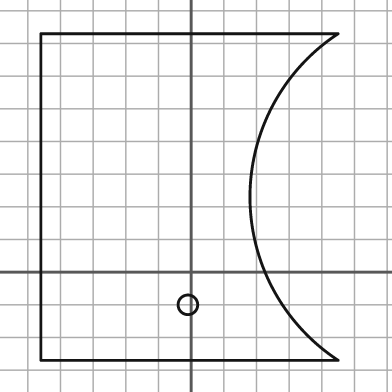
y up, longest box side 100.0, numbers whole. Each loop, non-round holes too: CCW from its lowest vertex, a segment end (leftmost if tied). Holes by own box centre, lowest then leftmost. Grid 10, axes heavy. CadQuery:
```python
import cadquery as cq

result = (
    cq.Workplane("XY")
    .moveTo(-46.0, -27.0)
    .lineTo(45.0, -27.0)
    .threePointArc((18.0, 23.0), (45.0, 73.0))
    .lineTo(-46.0, 73.0)
    .close()
    .moveTo(-1.0, -10.0)
    .circle(3.0)
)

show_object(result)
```